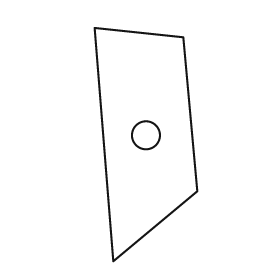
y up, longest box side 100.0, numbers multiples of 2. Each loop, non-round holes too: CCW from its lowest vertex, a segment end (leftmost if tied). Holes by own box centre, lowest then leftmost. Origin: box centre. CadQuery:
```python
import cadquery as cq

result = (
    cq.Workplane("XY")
    .moveTo(-14.0, -50.0)
    .lineTo(22.0, -20.0)
    .lineTo(16.0, 46.0)
    .lineTo(-22.0, 50.0)
    .close()
    .moveTo(0.0, 4.0)
    .circle(6.0)
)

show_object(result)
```